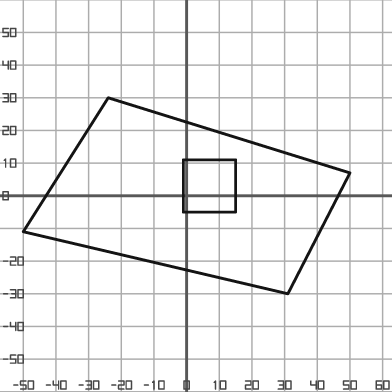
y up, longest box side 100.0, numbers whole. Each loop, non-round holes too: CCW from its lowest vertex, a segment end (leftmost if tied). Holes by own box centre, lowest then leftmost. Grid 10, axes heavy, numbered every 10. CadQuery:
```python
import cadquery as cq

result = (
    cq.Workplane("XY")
    .moveTo(31.0, -30.0)
    .lineTo(50.0, 7.0)
    .lineTo(-24.0, 30.0)
    .lineTo(-50.0, -11.0)
    .close()
    .moveTo(-1.0, -5.0)
    .lineTo(15.0, -5.0)
    .lineTo(15.0, 11.0)
    .lineTo(-1.0, 11.0)
    .close()
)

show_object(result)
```